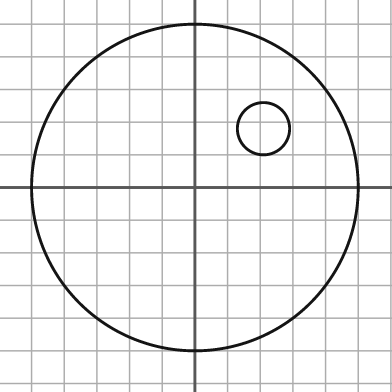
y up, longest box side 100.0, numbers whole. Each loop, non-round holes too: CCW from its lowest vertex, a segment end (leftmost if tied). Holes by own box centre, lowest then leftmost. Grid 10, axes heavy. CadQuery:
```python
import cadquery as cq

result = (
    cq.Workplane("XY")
    .moveTo(0.0, 0.0)
    .circle(50.0)
    .moveTo(21.0, 18.0)
    .circle(8.0)
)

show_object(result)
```